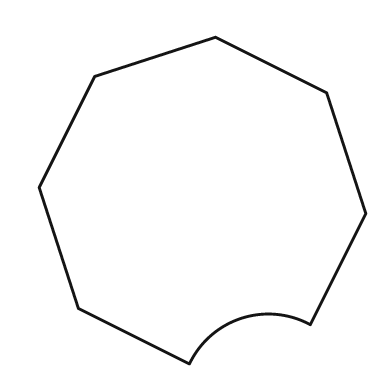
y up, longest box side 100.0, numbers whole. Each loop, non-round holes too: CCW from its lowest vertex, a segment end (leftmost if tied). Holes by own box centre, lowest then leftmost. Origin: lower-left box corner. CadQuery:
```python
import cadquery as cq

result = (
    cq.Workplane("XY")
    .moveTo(46.0, 0.0)
    .threePointArc((62.0, 14.0), (83.0, 12.0))
    .lineTo(100.0, 46.0)
    .lineTo(88.0, 83.0)
    .lineTo(54.0, 100.0)
    .lineTo(17.0, 88.0)
    .lineTo(0.0, 54.0)
    .lineTo(12.0, 17.0)
    .close()
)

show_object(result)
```